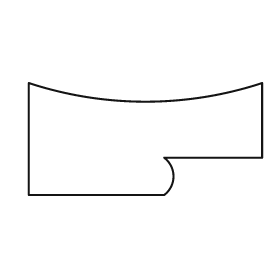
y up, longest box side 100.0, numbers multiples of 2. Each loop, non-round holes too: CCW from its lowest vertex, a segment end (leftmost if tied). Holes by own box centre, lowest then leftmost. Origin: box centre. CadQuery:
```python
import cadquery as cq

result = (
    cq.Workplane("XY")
    .moveTo(-50.0, -24.0)
    .lineTo(8.0, -24.0)
    .threePointArc((12.0, -16.0), (8.0, -8.0))
    .lineTo(50.0, -8.0)
    .lineTo(50.0, 24.0)
    .threePointArc((0.0, 16.0), (-50.0, 24.0))
    .close()
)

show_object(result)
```